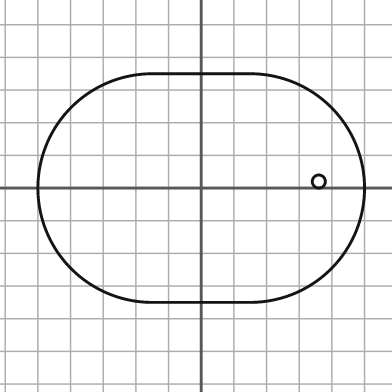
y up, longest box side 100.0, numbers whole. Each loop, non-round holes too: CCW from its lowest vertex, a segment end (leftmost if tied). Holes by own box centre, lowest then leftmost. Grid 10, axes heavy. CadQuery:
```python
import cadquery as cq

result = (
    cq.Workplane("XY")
    .moveTo(-15.0, -35.0)
    .lineTo(15.0, -35.0)
    .threePointArc((50.0, 0.0), (15.0, 35.0))
    .lineTo(-15.0, 35.0)
    .threePointArc((-50.0, 0.0), (-15.0, -35.0))
    .close()
    .moveTo(36.0, 2.0)
    .circle(2.0)
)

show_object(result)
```